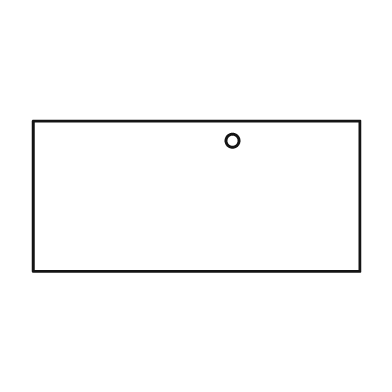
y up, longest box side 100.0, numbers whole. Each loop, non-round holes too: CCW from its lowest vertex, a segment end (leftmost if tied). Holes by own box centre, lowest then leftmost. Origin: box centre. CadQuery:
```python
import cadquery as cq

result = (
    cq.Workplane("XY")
    .moveTo(-50.0, -23.0)
    .lineTo(50.0, -23.0)
    .lineTo(50.0, 23.0)
    .lineTo(-50.0, 23.0)
    .close()
    .moveTo(11.0, 17.0)
    .circle(2.0)
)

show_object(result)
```